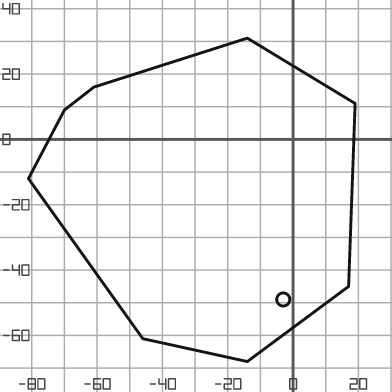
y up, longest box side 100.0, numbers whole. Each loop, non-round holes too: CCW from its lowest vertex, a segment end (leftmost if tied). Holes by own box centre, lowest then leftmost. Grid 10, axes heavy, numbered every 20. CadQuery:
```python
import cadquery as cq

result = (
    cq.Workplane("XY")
    .moveTo(-14.0, -68.0)
    .lineTo(17.0, -45.0)
    .lineTo(19.0, 11.0)
    .lineTo(-14.0, 31.0)
    .lineTo(-61.0, 16.0)
    .lineTo(-70.0, 9.0)
    .lineTo(-81.0, -12.0)
    .lineTo(-46.0, -61.0)
    .close()
    .moveTo(-3.0, -49.0)
    .circle(2.0)
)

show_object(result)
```